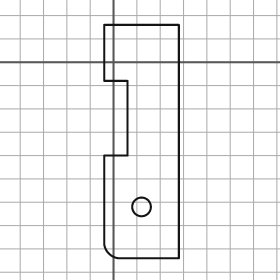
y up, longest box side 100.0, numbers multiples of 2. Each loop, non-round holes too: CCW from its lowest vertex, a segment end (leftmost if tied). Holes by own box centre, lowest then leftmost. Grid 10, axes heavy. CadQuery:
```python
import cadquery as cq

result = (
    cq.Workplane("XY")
    .moveTo(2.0, -84.0)
    .lineTo(28.0, -84.0)
    .lineTo(28.0, 16.0)
    .lineTo(-4.0, 16.0)
    .lineTo(-4.0, -8.0)
    .lineTo(6.0, -8.0)
    .lineTo(6.0, -40.0)
    .lineTo(-4.0, -40.0)
    .lineTo(-4.0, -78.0)
    .threePointArc((-2.0, -82.0), (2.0, -84.0))
    .close()
    .moveTo(12.0, -62.0)
    .circle(4.0)
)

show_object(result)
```